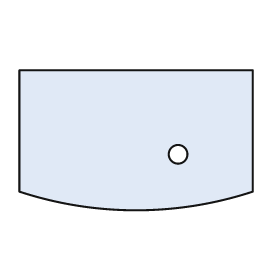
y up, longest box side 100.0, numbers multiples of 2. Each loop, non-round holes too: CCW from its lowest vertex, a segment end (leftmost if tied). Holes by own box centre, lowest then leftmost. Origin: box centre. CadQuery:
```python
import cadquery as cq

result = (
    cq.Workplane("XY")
    .moveTo(-50.0, -22.0)
    .threePointArc((0.0, -30.0), (50.0, -22.0))
    .lineTo(50.0, 30.0)
    .lineTo(-50.0, 30.0)
    .close()
    .moveTo(18.0, -6.0)
    .circle(4.0)
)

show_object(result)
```